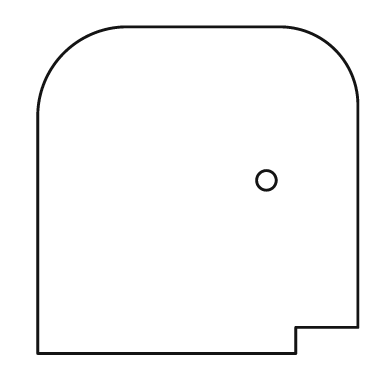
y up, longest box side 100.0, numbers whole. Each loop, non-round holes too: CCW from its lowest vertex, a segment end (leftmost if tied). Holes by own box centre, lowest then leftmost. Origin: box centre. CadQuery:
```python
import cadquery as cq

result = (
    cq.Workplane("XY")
    .moveTo(-49.0, -50.0)
    .lineTo(30.0, -50.0)
    .lineTo(30.0, -42.0)
    .lineTo(49.0, -42.0)
    .lineTo(49.0, 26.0)
    .threePointArc((42.0, 43.0), (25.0, 50.0))
    .lineTo(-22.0, 50.0)
    .threePointArc((-41.0, 42.0), (-49.0, 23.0))
    .close()
    .moveTo(21.0, 3.0)
    .circle(3.0)
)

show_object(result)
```